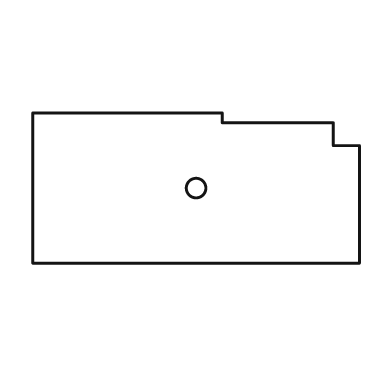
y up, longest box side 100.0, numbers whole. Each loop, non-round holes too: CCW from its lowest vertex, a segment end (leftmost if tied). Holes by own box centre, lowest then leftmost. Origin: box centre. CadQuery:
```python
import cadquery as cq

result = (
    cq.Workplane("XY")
    .moveTo(-50.0, -23.0)
    .lineTo(50.0, -23.0)
    .lineTo(50.0, 13.0)
    .lineTo(42.0, 13.0)
    .lineTo(42.0, 20.0)
    .lineTo(8.0, 20.0)
    .lineTo(8.0, 23.0)
    .lineTo(-50.0, 23.0)
    .close()
    .moveTo(0.0, 0.0)
    .circle(3.0)
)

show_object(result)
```